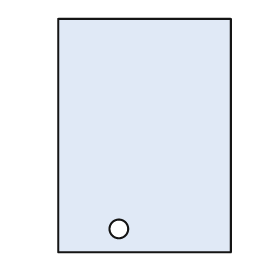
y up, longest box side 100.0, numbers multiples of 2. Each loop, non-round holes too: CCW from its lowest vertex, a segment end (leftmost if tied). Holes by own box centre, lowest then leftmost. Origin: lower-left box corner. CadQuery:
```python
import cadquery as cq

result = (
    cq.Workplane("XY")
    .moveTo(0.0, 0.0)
    .lineTo(74.0, 0.0)
    .lineTo(74.0, 100.0)
    .lineTo(0.0, 100.0)
    .close()
    .moveTo(26.0, 10.0)
    .circle(4.0)
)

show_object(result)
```